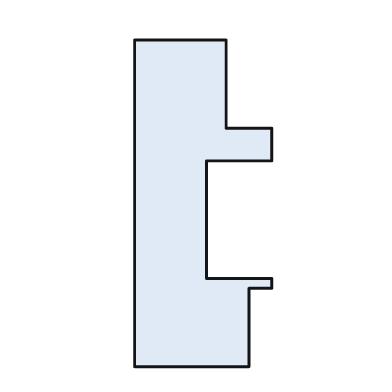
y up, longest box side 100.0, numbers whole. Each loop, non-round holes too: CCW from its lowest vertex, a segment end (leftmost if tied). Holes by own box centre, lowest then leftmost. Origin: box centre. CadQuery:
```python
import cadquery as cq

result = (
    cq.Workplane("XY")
    .moveTo(-21.0, -50.0)
    .lineTo(14.0, -50.0)
    .lineTo(14.0, -26.0)
    .lineTo(21.0, -26.0)
    .lineTo(21.0, -23.0)
    .lineTo(1.0, -23.0)
    .lineTo(1.0, 13.0)
    .lineTo(21.0, 13.0)
    .lineTo(21.0, 23.0)
    .lineTo(7.0, 23.0)
    .lineTo(7.0, 50.0)
    .lineTo(-21.0, 50.0)
    .close()
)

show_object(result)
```